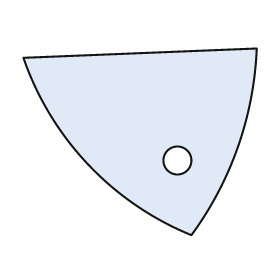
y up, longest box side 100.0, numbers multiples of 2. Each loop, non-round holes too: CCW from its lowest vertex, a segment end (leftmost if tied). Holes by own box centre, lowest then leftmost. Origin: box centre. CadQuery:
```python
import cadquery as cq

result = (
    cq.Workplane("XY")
    .moveTo(22.0, -40.0)
    .threePointArc((42.0, -2.0), (50.0, 40.0))
    .lineTo(-50.0, 36.0)
    .threePointArc((-22.0, -10.0), (22.0, -40.0))
    .close()
    .moveTo(16.0, -8.0)
    .circle(6.0)
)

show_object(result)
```